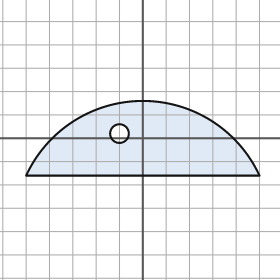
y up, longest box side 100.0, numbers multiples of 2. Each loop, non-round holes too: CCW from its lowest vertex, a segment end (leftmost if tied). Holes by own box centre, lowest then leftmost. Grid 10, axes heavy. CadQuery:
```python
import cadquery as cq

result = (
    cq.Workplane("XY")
    .moveTo(-50.0, -16.0)
    .lineTo(50.0, -16.0)
    .threePointArc((0.0, 16.0), (-50.0, -16.0))
    .close()
    .moveTo(-10.0, 2.0)
    .circle(4.0)
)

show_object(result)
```